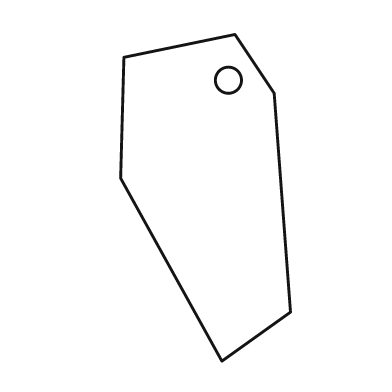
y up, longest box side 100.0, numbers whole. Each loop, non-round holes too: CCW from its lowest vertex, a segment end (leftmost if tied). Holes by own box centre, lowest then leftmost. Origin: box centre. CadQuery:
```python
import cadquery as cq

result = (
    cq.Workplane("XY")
    .moveTo(5.0, -50.0)
    .lineTo(26.0, -35.0)
    .lineTo(21.0, 32.0)
    .lineTo(9.0, 50.0)
    .lineTo(-25.0, 43.0)
    .lineTo(-26.0, 6.0)
    .close()
    .moveTo(7.0, 36.0)
    .circle(4.0)
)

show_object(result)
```